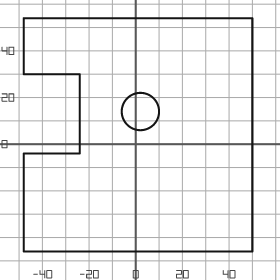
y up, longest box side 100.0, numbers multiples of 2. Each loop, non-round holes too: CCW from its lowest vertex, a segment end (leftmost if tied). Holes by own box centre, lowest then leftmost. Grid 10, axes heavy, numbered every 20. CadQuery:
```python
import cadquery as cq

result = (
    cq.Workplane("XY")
    .moveTo(-48.0, -46.0)
    .lineTo(50.0, -46.0)
    .lineTo(50.0, 54.0)
    .lineTo(-48.0, 54.0)
    .lineTo(-48.0, 30.0)
    .lineTo(-24.0, 30.0)
    .lineTo(-24.0, -4.0)
    .lineTo(-48.0, -4.0)
    .close()
    .moveTo(2.0, 14.0)
    .circle(8.0)
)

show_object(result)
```